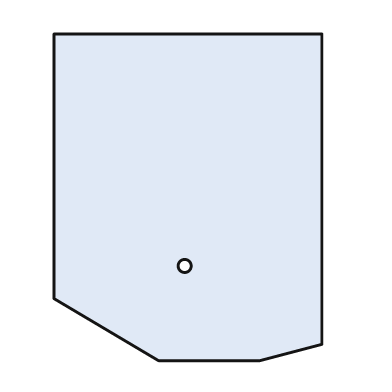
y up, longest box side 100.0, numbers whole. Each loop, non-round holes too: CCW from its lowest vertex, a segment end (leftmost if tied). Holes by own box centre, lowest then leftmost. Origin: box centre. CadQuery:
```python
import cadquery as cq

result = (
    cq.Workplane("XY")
    .moveTo(-9.0, -50.0)
    .lineTo(22.0, -50.0)
    .lineTo(41.0, -45.0)
    .lineTo(41.0, 50.0)
    .lineTo(-41.0, 50.0)
    .lineTo(-41.0, -31.0)
    .close()
    .moveTo(-1.0, -21.0)
    .circle(2.0)
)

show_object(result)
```